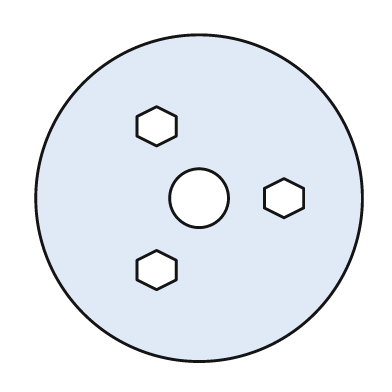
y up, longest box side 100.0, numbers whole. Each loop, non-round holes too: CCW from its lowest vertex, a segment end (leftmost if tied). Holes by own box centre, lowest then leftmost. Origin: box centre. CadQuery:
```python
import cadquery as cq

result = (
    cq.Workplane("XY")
    .moveTo(0.0, 0.0)
    .circle(50.0)
    .moveTo(-13.0, -28.0)
    .lineTo(-7.0, -25.0)
    .lineTo(-7.0, -19.0)
    .lineTo(-13.0, -16.0)
    .lineTo(-19.0, -19.0)
    .lineTo(-19.0, -25.0)
    .close()
    .moveTo(0.0, 0.0)
    .circle(9.0)
    .moveTo(26.0, -6.0)
    .lineTo(32.0, -3.0)
    .lineTo(32.0, 3.0)
    .lineTo(26.0, 6.0)
    .lineTo(20.0, 3.0)
    .lineTo(20.0, -3.0)
    .close()
    .moveTo(-13.0, 16.0)
    .lineTo(-7.0, 19.0)
    .lineTo(-7.0, 25.0)
    .lineTo(-13.0, 28.0)
    .lineTo(-19.0, 25.0)
    .lineTo(-19.0, 19.0)
    .close()
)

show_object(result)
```